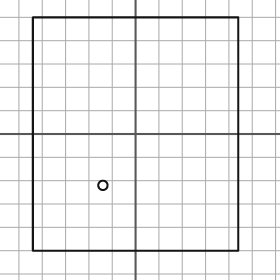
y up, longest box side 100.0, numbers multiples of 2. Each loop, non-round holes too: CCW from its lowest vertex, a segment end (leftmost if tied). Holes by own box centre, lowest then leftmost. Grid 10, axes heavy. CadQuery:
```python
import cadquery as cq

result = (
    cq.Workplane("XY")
    .moveTo(-44.0, -50.0)
    .lineTo(44.0, -50.0)
    .lineTo(44.0, 50.0)
    .lineTo(-44.0, 50.0)
    .close()
    .moveTo(-14.0, -22.0)
    .circle(2.0)
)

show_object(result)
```